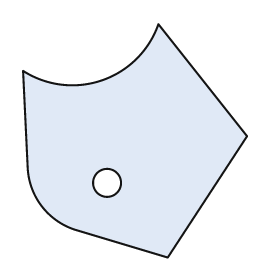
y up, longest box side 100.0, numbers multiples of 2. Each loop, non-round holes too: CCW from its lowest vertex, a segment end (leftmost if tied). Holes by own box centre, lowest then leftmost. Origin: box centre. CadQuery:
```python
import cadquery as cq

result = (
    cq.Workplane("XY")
    .moveTo(14.0, -50.0)
    .lineTo(48.0, 2.0)
    .lineTo(10.0, 50.0)
    .threePointArc((-14.0, 26.0), (-48.0, 30.0))
    .lineTo(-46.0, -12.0)
    .threePointArc((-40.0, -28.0), (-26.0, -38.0))
    .close()
    .moveTo(-12.0, -18.0)
    .circle(6.0)
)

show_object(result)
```